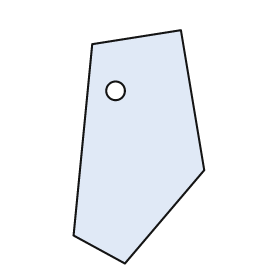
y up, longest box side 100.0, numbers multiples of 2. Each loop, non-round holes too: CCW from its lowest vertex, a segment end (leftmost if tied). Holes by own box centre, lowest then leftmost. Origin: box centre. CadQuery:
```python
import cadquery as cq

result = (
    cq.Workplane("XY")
    .moveTo(-6.0, -50.0)
    .lineTo(28.0, -10.0)
    .lineTo(18.0, 50.0)
    .lineTo(-20.0, 44.0)
    .lineTo(-28.0, -38.0)
    .close()
    .moveTo(-10.0, 24.0)
    .circle(4.0)
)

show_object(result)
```